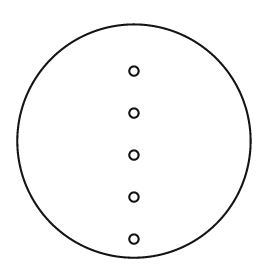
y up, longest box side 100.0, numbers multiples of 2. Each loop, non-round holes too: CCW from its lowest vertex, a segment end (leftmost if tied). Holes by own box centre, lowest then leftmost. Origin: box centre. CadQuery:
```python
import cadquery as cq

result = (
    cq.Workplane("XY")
    .moveTo(0.0, 0.0)
    .circle(50.0)
    .moveTo(0.0, -42.0)
    .circle(2.0)
    .moveTo(0.0, -24.0)
    .circle(2.0)
    .moveTo(0.0, -6.0)
    .circle(2.0)
    .moveTo(0.0, 12.0)
    .circle(2.0)
    .moveTo(0.0, 30.0)
    .circle(2.0)
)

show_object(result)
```